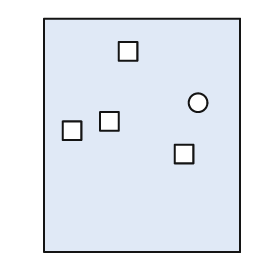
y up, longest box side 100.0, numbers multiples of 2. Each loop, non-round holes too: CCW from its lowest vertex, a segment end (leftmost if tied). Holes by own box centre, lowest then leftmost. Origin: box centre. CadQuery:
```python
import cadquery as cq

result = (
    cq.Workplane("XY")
    .moveTo(-42.0, -50.0)
    .lineTo(42.0, -50.0)
    .lineTo(42.0, 50.0)
    .lineTo(-42.0, 50.0)
    .close()
    .moveTo(14.0, -12.0)
    .lineTo(22.0, -12.0)
    .lineTo(22.0, -4.0)
    .lineTo(14.0, -4.0)
    .close()
    .moveTo(-34.0, -2.0)
    .lineTo(-26.0, -2.0)
    .lineTo(-26.0, 6.0)
    .lineTo(-34.0, 6.0)
    .close()
    .moveTo(-18.0, 2.0)
    .lineTo(-10.0, 2.0)
    .lineTo(-10.0, 10.0)
    .lineTo(-18.0, 10.0)
    .close()
    .moveTo(24.0, 14.0)
    .circle(4.0)
    .moveTo(-10.0, 32.0)
    .lineTo(-2.0, 32.0)
    .lineTo(-2.0, 40.0)
    .lineTo(-10.0, 40.0)
    .close()
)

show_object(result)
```